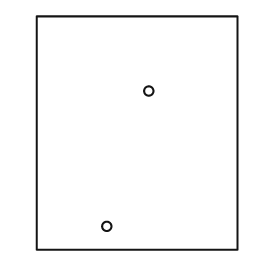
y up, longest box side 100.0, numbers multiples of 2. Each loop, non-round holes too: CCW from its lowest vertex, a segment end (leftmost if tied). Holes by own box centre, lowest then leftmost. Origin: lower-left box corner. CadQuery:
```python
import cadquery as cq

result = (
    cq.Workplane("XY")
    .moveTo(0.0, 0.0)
    .lineTo(86.0, 0.0)
    .lineTo(86.0, 100.0)
    .lineTo(0.0, 100.0)
    .close()
    .moveTo(30.0, 10.0)
    .circle(2.0)
    .moveTo(48.0, 68.0)
    .circle(2.0)
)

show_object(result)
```